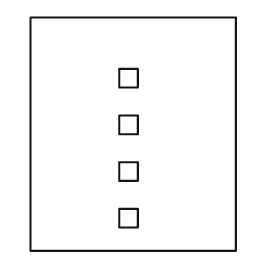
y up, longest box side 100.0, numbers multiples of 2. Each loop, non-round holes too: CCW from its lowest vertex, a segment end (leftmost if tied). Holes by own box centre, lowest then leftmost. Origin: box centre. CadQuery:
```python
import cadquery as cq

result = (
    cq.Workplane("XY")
    .moveTo(-44.0, -50.0)
    .lineTo(44.0, -50.0)
    .lineTo(44.0, 50.0)
    .lineTo(-44.0, 50.0)
    .close()
    .moveTo(-6.0, -40.0)
    .lineTo(2.0, -40.0)
    .lineTo(2.0, -32.0)
    .lineTo(-6.0, -32.0)
    .close()
    .moveTo(-6.0, -20.0)
    .lineTo(2.0, -20.0)
    .lineTo(2.0, -12.0)
    .lineTo(-6.0, -12.0)
    .close()
    .moveTo(-6.0, 0.0)
    .lineTo(2.0, 0.0)
    .lineTo(2.0, 8.0)
    .lineTo(-6.0, 8.0)
    .close()
    .moveTo(-6.0, 20.0)
    .lineTo(2.0, 20.0)
    .lineTo(2.0, 28.0)
    .lineTo(-6.0, 28.0)
    .close()
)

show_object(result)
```